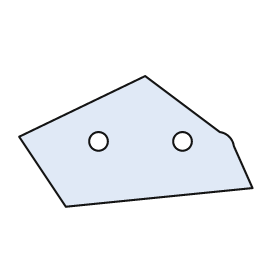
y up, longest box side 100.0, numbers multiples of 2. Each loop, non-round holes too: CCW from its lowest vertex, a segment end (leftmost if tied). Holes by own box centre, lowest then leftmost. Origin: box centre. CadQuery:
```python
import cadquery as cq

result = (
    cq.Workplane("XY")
    .moveTo(-30.0, -28.0)
    .lineTo(50.0, -20.0)
    .lineTo(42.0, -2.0)
    .threePointArc((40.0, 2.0), (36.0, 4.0))
    .lineTo(4.0, 28.0)
    .lineTo(-50.0, 2.0)
    .close()
    .moveTo(-16.0, 0.0)
    .circle(4.0)
    .moveTo(20.0, 0.0)
    .circle(4.0)
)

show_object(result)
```